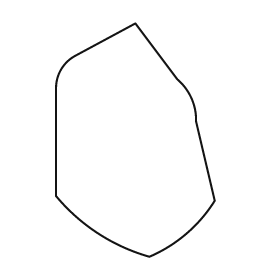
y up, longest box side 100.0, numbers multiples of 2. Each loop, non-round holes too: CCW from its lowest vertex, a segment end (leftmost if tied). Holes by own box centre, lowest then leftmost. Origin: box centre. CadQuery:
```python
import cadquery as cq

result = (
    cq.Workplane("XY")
    .moveTo(6.0, -50.0)
    .threePointArc((22.0, -40.0), (34.0, -26.0))
    .lineTo(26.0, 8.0)
    .threePointArc((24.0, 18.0), (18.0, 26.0))
    .lineTo(0.0, 50.0)
    .lineTo(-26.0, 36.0)
    .threePointArc((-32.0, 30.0), (-34.0, 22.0))
    .lineTo(-34.0, -24.0)
    .threePointArc((-16.0, -40.0), (6.0, -50.0))
    .close()
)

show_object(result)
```